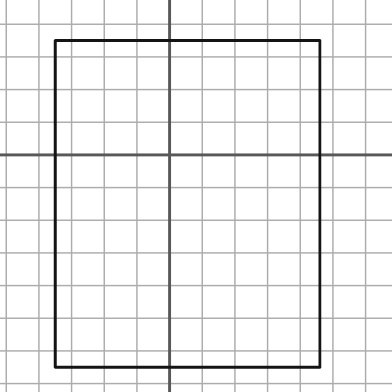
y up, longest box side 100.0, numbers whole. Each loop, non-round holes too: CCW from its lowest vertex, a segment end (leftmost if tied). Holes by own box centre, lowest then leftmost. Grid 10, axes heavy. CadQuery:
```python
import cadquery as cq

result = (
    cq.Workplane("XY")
    .moveTo(-35.0, -65.0)
    .lineTo(46.0, -65.0)
    .lineTo(46.0, 35.0)
    .lineTo(-35.0, 35.0)
    .close()
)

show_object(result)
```